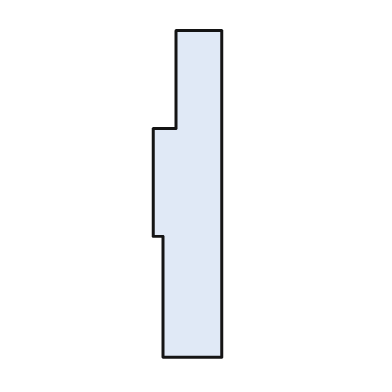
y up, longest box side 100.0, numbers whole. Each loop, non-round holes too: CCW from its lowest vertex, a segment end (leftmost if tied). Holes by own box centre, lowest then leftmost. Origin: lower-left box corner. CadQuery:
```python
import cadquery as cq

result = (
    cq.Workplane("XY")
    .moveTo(3.0, 0.0)
    .lineTo(21.0, 0.0)
    .lineTo(21.0, 100.0)
    .lineTo(7.0, 100.0)
    .lineTo(7.0, 70.0)
    .lineTo(0.0, 70.0)
    .lineTo(0.0, 37.0)
    .lineTo(3.0, 37.0)
    .close()
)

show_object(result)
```